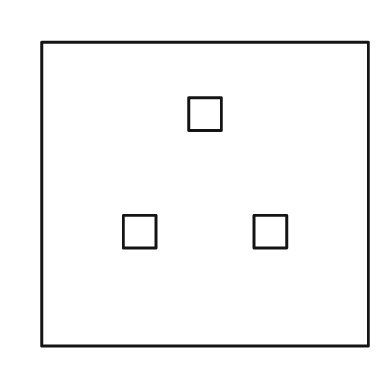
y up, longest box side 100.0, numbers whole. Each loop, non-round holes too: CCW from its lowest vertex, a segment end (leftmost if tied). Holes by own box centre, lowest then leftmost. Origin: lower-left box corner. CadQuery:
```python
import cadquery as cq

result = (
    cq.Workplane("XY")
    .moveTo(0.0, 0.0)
    .lineTo(100.0, 0.0)
    .lineTo(100.0, 93.0)
    .lineTo(0.0, 93.0)
    .close()
    .moveTo(25.0, 30.0)
    .lineTo(35.0, 30.0)
    .lineTo(35.0, 40.0)
    .lineTo(25.0, 40.0)
    .close()
    .moveTo(65.0, 30.0)
    .lineTo(75.0, 30.0)
    .lineTo(75.0, 40.0)
    .lineTo(65.0, 40.0)
    .close()
    .moveTo(45.0, 66.0)
    .lineTo(55.0, 66.0)
    .lineTo(55.0, 76.0)
    .lineTo(45.0, 76.0)
    .close()
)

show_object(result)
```